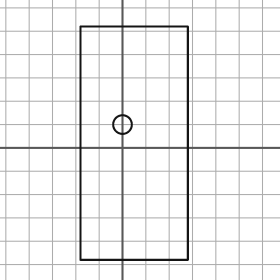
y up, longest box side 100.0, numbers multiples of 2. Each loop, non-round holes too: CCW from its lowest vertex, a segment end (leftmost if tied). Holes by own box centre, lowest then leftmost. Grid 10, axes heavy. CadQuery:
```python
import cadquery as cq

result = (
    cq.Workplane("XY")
    .moveTo(-18.0, -48.0)
    .lineTo(28.0, -48.0)
    .lineTo(28.0, 52.0)
    .lineTo(-18.0, 52.0)
    .close()
    .moveTo(0.0, 10.0)
    .circle(4.0)
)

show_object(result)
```